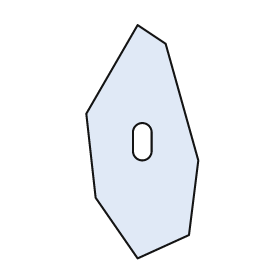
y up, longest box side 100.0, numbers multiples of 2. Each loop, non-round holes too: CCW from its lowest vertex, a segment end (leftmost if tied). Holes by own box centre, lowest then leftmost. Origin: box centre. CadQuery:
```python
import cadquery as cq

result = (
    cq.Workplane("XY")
    .moveTo(-2.0, -50.0)
    .lineTo(20.0, -40.0)
    .lineTo(24.0, -8.0)
    .lineTo(10.0, 42.0)
    .lineTo(-2.0, 50.0)
    .lineTo(-24.0, 12.0)
    .lineTo(-20.0, -24.0)
    .close()
    .moveTo(-4.0, -4.0)
    .threePointArc((0.0, -8.0), (4.0, -4.0))
    .lineTo(4.0, 4.0)
    .threePointArc((0.0, 8.0), (-4.0, 4.0))
    .close()
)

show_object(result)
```